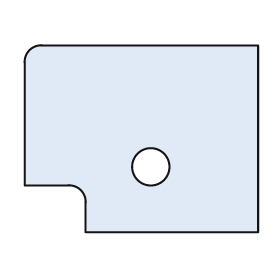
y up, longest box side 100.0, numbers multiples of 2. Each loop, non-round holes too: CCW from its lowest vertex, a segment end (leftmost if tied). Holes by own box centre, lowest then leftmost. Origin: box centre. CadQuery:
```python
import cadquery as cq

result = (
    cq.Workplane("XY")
    .moveTo(-24.0, -40.0)
    .lineTo(50.0, -40.0)
    .lineTo(50.0, 40.0)
    .lineTo(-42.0, 40.0)
    .threePointArc((-48.0, 38.0), (-50.0, 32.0))
    .lineTo(-50.0, -20.0)
    .lineTo(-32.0, -20.0)
    .threePointArc((-26.0, -22.0), (-24.0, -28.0))
    .close()
    .moveTo(4.0, -12.0)
    .circle(8.0)
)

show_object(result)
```